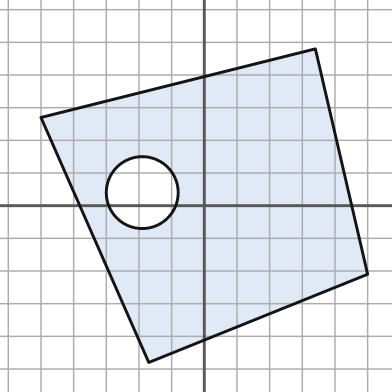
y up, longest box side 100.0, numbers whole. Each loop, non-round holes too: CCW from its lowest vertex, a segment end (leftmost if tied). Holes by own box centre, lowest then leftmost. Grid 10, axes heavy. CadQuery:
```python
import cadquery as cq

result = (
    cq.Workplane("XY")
    .moveTo(-17.0, -48.0)
    .lineTo(50.0, -21.0)
    .lineTo(34.0, 48.0)
    .lineTo(-50.0, 27.0)
    .close()
    .moveTo(-19.0, 4.0)
    .circle(11.0)
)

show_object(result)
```